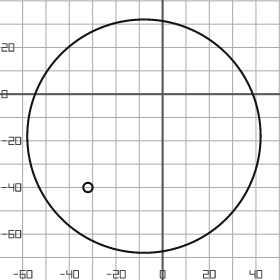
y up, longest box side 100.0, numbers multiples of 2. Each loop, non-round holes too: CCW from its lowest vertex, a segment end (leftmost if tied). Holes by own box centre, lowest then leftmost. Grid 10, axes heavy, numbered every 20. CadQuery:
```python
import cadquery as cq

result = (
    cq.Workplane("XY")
    .moveTo(-8.0, -18.0)
    .circle(50.0)
    .moveTo(-32.0, -40.0)
    .circle(2.0)
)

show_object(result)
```